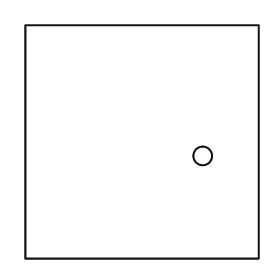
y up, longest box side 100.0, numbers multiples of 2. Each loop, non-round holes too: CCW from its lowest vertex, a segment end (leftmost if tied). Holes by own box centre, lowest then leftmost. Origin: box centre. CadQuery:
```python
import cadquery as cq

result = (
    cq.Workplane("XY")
    .moveTo(-50.0, -50.0)
    .lineTo(50.0, -50.0)
    .lineTo(50.0, 50.0)
    .lineTo(-50.0, 50.0)
    .close()
    .moveTo(26.0, -6.0)
    .circle(4.0)
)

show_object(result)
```